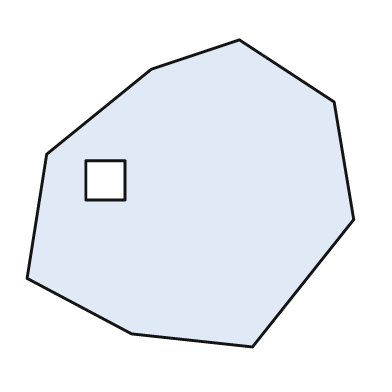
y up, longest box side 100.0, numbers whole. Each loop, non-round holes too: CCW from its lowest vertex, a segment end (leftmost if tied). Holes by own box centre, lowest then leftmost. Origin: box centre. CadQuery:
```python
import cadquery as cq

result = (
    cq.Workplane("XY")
    .moveTo(19.0, -47.0)
    .lineTo(50.0, -8.0)
    .lineTo(44.0, 28.0)
    .lineTo(15.0, 47.0)
    .lineTo(-12.0, 38.0)
    .lineTo(-44.0, 12.0)
    .lineTo(-50.0, -26.0)
    .lineTo(-18.0, -43.0)
    .close()
    .moveTo(-32.0, -2.0)
    .lineTo(-20.0, -2.0)
    .lineTo(-20.0, 10.0)
    .lineTo(-32.0, 10.0)
    .close()
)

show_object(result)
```